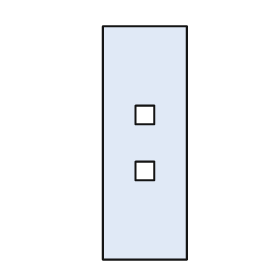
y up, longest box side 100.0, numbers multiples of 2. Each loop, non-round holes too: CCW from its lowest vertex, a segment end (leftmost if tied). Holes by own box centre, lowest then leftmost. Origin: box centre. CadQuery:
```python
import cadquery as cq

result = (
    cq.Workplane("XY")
    .moveTo(-18.0, -50.0)
    .lineTo(18.0, -50.0)
    .lineTo(18.0, 50.0)
    .lineTo(-18.0, 50.0)
    .close()
    .moveTo(-4.0, -16.0)
    .lineTo(4.0, -16.0)
    .lineTo(4.0, -8.0)
    .lineTo(-4.0, -8.0)
    .close()
    .moveTo(-4.0, 8.0)
    .lineTo(4.0, 8.0)
    .lineTo(4.0, 16.0)
    .lineTo(-4.0, 16.0)
    .close()
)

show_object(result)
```